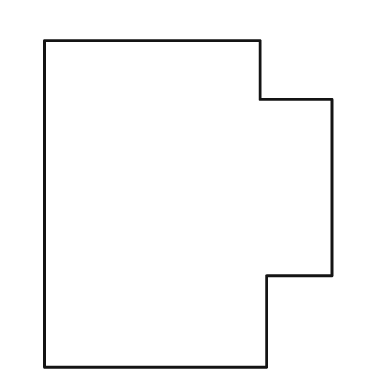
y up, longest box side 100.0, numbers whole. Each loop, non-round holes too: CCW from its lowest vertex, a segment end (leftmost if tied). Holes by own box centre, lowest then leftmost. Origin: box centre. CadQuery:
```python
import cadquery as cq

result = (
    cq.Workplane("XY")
    .moveTo(-44.0, -50.0)
    .lineTo(24.0, -50.0)
    .lineTo(24.0, -22.0)
    .lineTo(44.0, -22.0)
    .lineTo(44.0, 32.0)
    .lineTo(22.0, 32.0)
    .lineTo(22.0, 50.0)
    .lineTo(-44.0, 50.0)
    .close()
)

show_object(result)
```